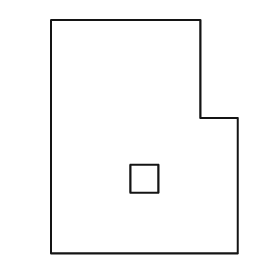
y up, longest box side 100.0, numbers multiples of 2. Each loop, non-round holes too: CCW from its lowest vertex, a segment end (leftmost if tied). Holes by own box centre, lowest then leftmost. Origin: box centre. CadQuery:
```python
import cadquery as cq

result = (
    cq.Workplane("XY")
    .moveTo(-40.0, -50.0)
    .lineTo(40.0, -50.0)
    .lineTo(40.0, 8.0)
    .lineTo(24.0, 8.0)
    .lineTo(24.0, 50.0)
    .lineTo(-40.0, 50.0)
    .close()
    .moveTo(-6.0, -24.0)
    .lineTo(6.0, -24.0)
    .lineTo(6.0, -12.0)
    .lineTo(-6.0, -12.0)
    .close()
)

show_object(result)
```